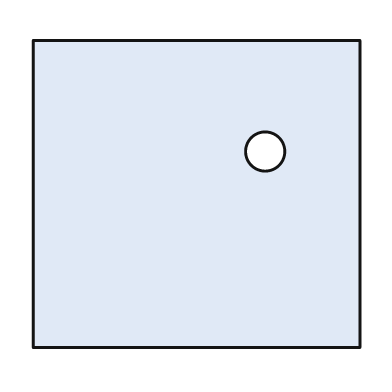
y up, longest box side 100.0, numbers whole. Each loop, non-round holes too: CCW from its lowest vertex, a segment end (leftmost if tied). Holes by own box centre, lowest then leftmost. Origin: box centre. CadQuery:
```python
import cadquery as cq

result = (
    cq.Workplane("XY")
    .moveTo(-50.0, -47.0)
    .lineTo(50.0, -47.0)
    .lineTo(50.0, 47.0)
    .lineTo(-50.0, 47.0)
    .close()
    .moveTo(21.0, 13.0)
    .circle(6.0)
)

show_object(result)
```